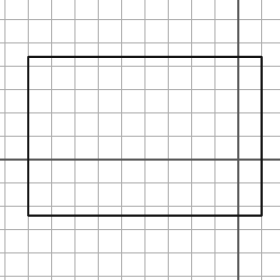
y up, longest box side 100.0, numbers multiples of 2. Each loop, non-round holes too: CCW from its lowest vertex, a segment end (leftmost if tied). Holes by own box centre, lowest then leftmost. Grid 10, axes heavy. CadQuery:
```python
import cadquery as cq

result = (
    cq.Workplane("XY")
    .moveTo(-90.0, -24.0)
    .lineTo(10.0, -24.0)
    .lineTo(10.0, 44.0)
    .lineTo(-90.0, 44.0)
    .close()
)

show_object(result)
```